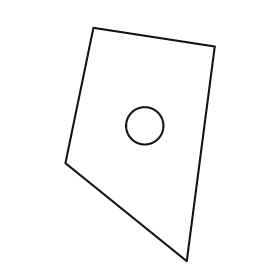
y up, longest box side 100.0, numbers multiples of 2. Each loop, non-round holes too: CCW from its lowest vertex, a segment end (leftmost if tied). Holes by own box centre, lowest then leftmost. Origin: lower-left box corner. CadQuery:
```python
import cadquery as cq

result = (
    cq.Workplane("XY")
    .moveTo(52.0, 0.0)
    .lineTo(64.0, 92.0)
    .lineTo(12.0, 100.0)
    .lineTo(0.0, 42.0)
    .close()
    .moveTo(34.0, 58.0)
    .circle(8.0)
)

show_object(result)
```